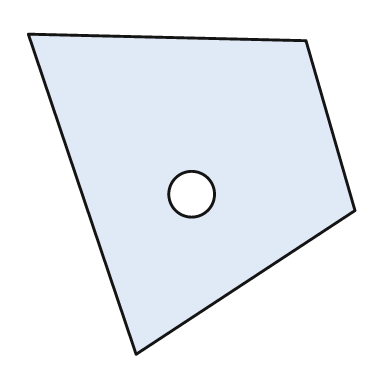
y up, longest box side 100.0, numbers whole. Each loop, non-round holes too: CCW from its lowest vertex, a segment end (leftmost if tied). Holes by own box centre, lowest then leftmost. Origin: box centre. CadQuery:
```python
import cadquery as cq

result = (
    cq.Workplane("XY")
    .moveTo(-17.0, -49.0)
    .lineTo(50.0, -5.0)
    .lineTo(35.0, 47.0)
    .lineTo(-50.0, 49.0)
    .close()
    .moveTo(0.0, 0.0)
    .circle(7.0)
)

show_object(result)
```